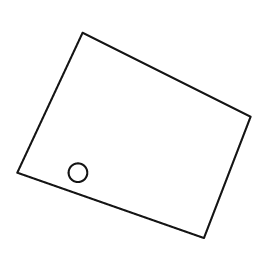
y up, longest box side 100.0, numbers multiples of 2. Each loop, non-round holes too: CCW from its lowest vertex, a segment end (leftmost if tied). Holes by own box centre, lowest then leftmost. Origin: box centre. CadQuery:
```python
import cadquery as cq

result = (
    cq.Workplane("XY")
    .moveTo(30.0, -44.0)
    .lineTo(50.0, 8.0)
    .lineTo(-22.0, 44.0)
    .lineTo(-50.0, -16.0)
    .close()
    .moveTo(-24.0, -16.0)
    .circle(4.0)
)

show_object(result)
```